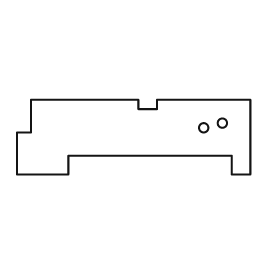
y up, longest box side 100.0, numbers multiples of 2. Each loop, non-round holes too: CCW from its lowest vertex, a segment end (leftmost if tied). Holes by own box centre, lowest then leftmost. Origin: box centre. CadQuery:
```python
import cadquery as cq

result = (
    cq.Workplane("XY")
    .moveTo(-50.0, -16.0)
    .lineTo(-28.0, -16.0)
    .lineTo(-28.0, -8.0)
    .lineTo(42.0, -8.0)
    .lineTo(42.0, -16.0)
    .lineTo(50.0, -16.0)
    .lineTo(50.0, 16.0)
    .lineTo(10.0, 16.0)
    .lineTo(10.0, 12.0)
    .lineTo(2.0, 12.0)
    .lineTo(2.0, 16.0)
    .lineTo(-44.0, 16.0)
    .lineTo(-44.0, 2.0)
    .lineTo(-50.0, 2.0)
    .close()
    .moveTo(30.0, 4.0)
    .circle(2.0)
    .moveTo(38.0, 6.0)
    .circle(2.0)
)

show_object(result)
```